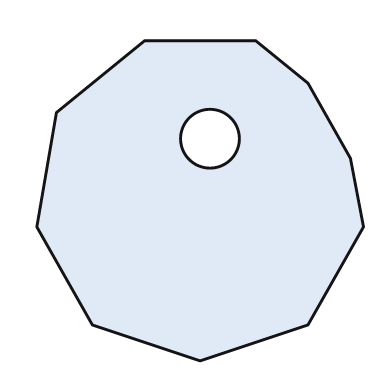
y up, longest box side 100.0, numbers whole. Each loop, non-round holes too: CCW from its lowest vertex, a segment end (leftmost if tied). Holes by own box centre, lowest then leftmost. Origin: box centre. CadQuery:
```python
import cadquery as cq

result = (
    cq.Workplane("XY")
    .moveTo(0.0, -49.0)
    .lineTo(33.0, -38.0)
    .lineTo(50.0, -8.0)
    .lineTo(46.0, 13.0)
    .lineTo(33.0, 36.0)
    .lineTo(17.0, 49.0)
    .lineTo(-17.0, 49.0)
    .lineTo(-44.0, 27.0)
    .lineTo(-50.0, -8.0)
    .lineTo(-33.0, -38.0)
    .close()
    .moveTo(3.0, 19.0)
    .circle(9.0)
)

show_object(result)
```